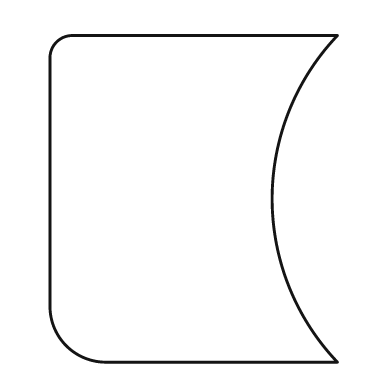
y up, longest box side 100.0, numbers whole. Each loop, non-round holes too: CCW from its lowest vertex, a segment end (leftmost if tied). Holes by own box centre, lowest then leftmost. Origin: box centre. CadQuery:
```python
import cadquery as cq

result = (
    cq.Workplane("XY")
    .moveTo(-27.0, -50.0)
    .lineTo(44.0, -50.0)
    .threePointArc((24.0, 0.0), (44.0, 50.0))
    .lineTo(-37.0, 50.0)
    .threePointArc((-42.0, 48.0), (-44.0, 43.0))
    .lineTo(-44.0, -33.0)
    .threePointArc((-39.0, -45.0), (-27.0, -50.0))
    .close()
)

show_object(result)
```